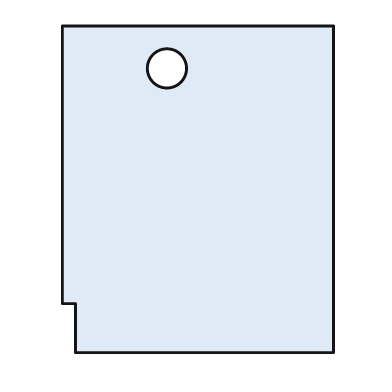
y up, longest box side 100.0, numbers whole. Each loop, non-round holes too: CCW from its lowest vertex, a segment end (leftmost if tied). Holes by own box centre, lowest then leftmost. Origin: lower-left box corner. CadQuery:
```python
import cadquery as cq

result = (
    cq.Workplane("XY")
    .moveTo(4.0, 0.0)
    .lineTo(83.0, 0.0)
    .lineTo(83.0, 100.0)
    .lineTo(0.0, 100.0)
    .lineTo(0.0, 15.0)
    .lineTo(4.0, 15.0)
    .close()
    .moveTo(32.0, 87.0)
    .circle(6.0)
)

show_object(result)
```